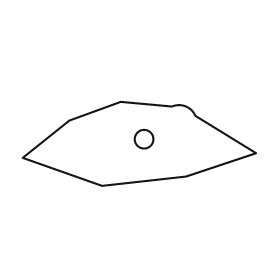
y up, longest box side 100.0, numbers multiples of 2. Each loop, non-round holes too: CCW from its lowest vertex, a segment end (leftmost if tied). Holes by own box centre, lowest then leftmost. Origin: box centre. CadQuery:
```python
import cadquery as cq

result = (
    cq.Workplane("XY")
    .moveTo(-16.0, -18.0)
    .lineTo(20.0, -14.0)
    .lineTo(50.0, -4.0)
    .lineTo(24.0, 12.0)
    .threePointArc((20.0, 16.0), (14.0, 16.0))
    .lineTo(-8.0, 18.0)
    .lineTo(-30.0, 10.0)
    .lineTo(-50.0, -6.0)
    .close()
    .moveTo(2.0, 2.0)
    .circle(4.0)
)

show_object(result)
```